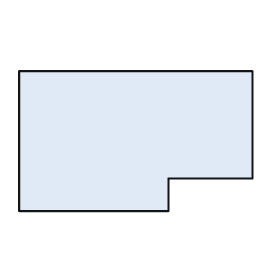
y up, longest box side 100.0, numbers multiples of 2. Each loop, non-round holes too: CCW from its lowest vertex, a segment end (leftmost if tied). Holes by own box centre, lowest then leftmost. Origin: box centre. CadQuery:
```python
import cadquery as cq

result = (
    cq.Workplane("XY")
    .moveTo(-50.0, -30.0)
    .lineTo(14.0, -30.0)
    .lineTo(14.0, -16.0)
    .lineTo(50.0, -16.0)
    .lineTo(50.0, 30.0)
    .lineTo(-50.0, 30.0)
    .close()
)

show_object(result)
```